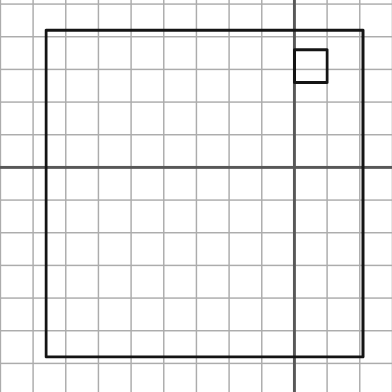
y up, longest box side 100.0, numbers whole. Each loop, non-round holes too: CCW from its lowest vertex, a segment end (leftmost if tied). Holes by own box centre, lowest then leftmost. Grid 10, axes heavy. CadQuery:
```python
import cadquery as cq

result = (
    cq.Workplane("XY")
    .moveTo(-76.0, -58.0)
    .lineTo(21.0, -58.0)
    .lineTo(21.0, 42.0)
    .lineTo(-76.0, 42.0)
    .close()
    .moveTo(0.0, 26.0)
    .lineTo(10.0, 26.0)
    .lineTo(10.0, 36.0)
    .lineTo(0.0, 36.0)
    .close()
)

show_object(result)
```